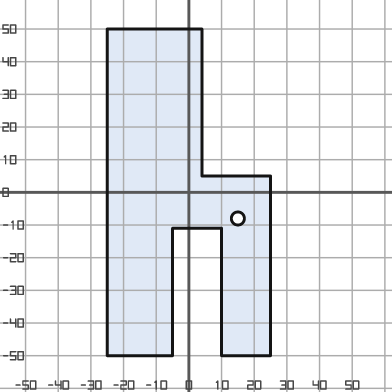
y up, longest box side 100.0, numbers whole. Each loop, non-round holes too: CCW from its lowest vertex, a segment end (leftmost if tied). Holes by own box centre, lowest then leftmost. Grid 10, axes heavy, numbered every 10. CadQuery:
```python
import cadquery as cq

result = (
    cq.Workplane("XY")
    .moveTo(-25.0, -50.0)
    .lineTo(-5.0, -50.0)
    .lineTo(-5.0, -11.0)
    .lineTo(10.0, -11.0)
    .lineTo(10.0, -50.0)
    .lineTo(25.0, -50.0)
    .lineTo(25.0, 5.0)
    .lineTo(4.0, 5.0)
    .lineTo(4.0, 50.0)
    .lineTo(-25.0, 50.0)
    .close()
    .moveTo(15.0, -8.0)
    .circle(2.0)
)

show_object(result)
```